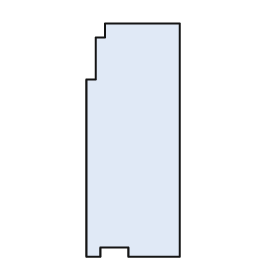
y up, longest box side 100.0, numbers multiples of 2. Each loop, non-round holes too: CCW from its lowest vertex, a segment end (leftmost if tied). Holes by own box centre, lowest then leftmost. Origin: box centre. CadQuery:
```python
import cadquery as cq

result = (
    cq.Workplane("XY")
    .moveTo(-20.0, -50.0)
    .lineTo(-14.0, -50.0)
    .lineTo(-14.0, -46.0)
    .lineTo(-2.0, -46.0)
    .lineTo(-2.0, -50.0)
    .lineTo(20.0, -50.0)
    .lineTo(20.0, 50.0)
    .lineTo(-12.0, 50.0)
    .lineTo(-12.0, 44.0)
    .lineTo(-16.0, 44.0)
    .lineTo(-16.0, 26.0)
    .lineTo(-20.0, 26.0)
    .close()
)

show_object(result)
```